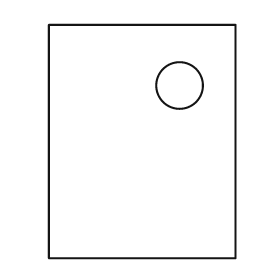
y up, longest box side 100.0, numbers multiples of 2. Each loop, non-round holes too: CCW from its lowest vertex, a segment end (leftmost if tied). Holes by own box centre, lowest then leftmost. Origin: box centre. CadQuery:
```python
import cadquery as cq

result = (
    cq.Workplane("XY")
    .moveTo(-40.0, -50.0)
    .lineTo(40.0, -50.0)
    .lineTo(40.0, 50.0)
    .lineTo(-40.0, 50.0)
    .close()
    .moveTo(16.0, 24.0)
    .circle(10.0)
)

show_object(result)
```